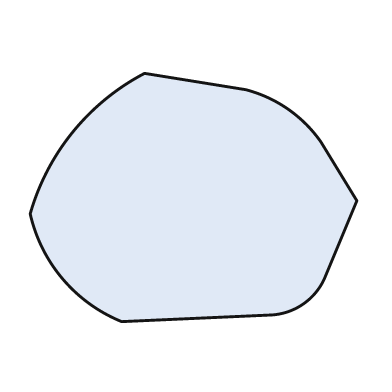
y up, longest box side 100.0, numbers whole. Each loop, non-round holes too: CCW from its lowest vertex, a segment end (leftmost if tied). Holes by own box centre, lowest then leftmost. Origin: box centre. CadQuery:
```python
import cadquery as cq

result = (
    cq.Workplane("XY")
    .moveTo(-22.0, -38.0)
    .lineTo(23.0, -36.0)
    .threePointArc((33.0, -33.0), (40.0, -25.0))
    .lineTo(50.0, -1.0)
    .lineTo(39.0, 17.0)
    .threePointArc((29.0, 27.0), (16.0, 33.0))
    .lineTo(-15.0, 38.0)
    .threePointArc((-37.0, 20.0), (-50.0, -5.0))
    .threePointArc((-40.0, -25.0), (-22.0, -38.0))
    .close()
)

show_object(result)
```